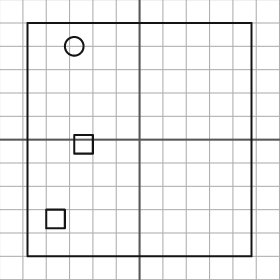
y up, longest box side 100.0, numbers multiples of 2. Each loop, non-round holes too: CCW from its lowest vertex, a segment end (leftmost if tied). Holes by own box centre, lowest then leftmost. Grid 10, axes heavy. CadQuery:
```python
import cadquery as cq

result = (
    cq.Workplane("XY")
    .moveTo(-48.0, -50.0)
    .lineTo(48.0, -50.0)
    .lineTo(48.0, 50.0)
    .lineTo(-48.0, 50.0)
    .close()
    .moveTo(-40.0, -38.0)
    .lineTo(-32.0, -38.0)
    .lineTo(-32.0, -30.0)
    .lineTo(-40.0, -30.0)
    .close()
    .moveTo(-28.0, -6.0)
    .lineTo(-20.0, -6.0)
    .lineTo(-20.0, 2.0)
    .lineTo(-28.0, 2.0)
    .close()
    .moveTo(-28.0, 40.0)
    .circle(4.0)
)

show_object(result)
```